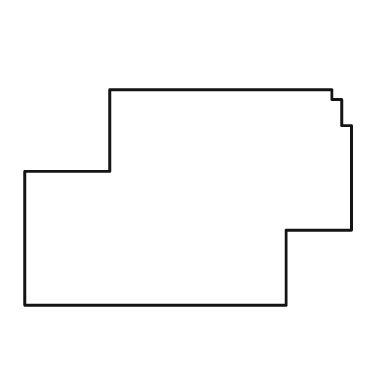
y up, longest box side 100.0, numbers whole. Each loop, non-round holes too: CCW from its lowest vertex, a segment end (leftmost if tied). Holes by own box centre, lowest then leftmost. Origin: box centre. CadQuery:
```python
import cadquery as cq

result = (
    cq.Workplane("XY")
    .moveTo(-50.0, -33.0)
    .lineTo(30.0, -33.0)
    .lineTo(30.0, -10.0)
    .lineTo(50.0, -10.0)
    .lineTo(50.0, 22.0)
    .lineTo(47.0, 22.0)
    .lineTo(47.0, 30.0)
    .lineTo(44.0, 30.0)
    .lineTo(44.0, 33.0)
    .lineTo(-24.0, 33.0)
    .lineTo(-24.0, 8.0)
    .lineTo(-50.0, 8.0)
    .close()
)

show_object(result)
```